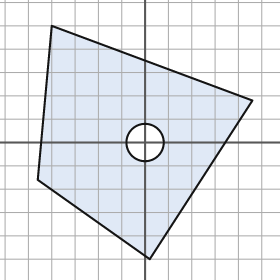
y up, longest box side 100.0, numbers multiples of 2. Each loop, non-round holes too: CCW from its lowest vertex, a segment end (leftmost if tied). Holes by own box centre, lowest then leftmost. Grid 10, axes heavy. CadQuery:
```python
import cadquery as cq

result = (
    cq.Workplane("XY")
    .moveTo(2.0, -50.0)
    .lineTo(46.0, 18.0)
    .lineTo(-40.0, 50.0)
    .lineTo(-46.0, -16.0)
    .close()
    .moveTo(0.0, 0.0)
    .circle(8.0)
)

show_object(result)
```